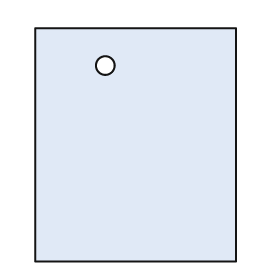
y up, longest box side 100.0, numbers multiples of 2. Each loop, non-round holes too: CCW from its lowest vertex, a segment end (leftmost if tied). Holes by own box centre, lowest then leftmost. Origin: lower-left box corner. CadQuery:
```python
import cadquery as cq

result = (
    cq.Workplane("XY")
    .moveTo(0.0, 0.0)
    .lineTo(86.0, 0.0)
    .lineTo(86.0, 100.0)
    .lineTo(0.0, 100.0)
    .close()
    .moveTo(30.0, 84.0)
    .circle(4.0)
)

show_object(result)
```